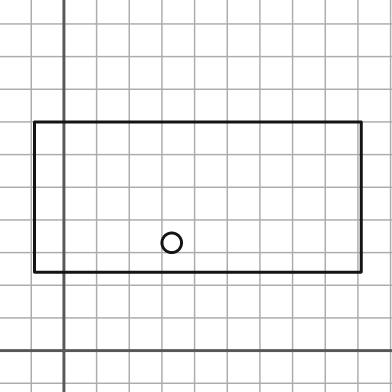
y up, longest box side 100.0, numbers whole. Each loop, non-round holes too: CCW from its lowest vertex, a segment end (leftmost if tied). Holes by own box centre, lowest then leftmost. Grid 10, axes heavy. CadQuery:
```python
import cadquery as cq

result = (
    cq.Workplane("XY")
    .moveTo(-9.0, 24.0)
    .lineTo(91.0, 24.0)
    .lineTo(91.0, 70.0)
    .lineTo(-9.0, 70.0)
    .close()
    .moveTo(33.0, 33.0)
    .circle(3.0)
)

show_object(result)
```